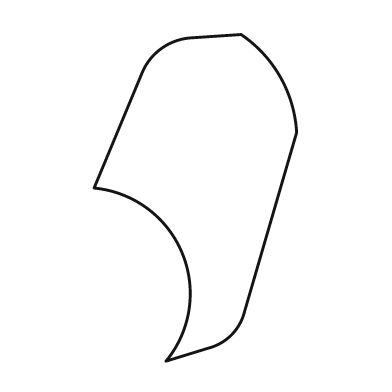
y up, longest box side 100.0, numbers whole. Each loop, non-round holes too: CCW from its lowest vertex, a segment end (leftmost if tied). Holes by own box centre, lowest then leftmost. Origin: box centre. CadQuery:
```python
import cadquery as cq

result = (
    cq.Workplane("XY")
    .moveTo(-9.0, -50.0)
    .lineTo(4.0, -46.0)
    .threePointArc((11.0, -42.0), (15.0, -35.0))
    .lineTo(31.0, 20.0)
    .threePointArc((26.0, 37.0), (14.0, 50.0))
    .lineTo(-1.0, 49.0)
    .threePointArc((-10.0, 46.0), (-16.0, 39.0))
    .lineTo(-31.0, 3.0)
    .threePointArc((-4.0, -17.0), (-9.0, -50.0))
    .close()
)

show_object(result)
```